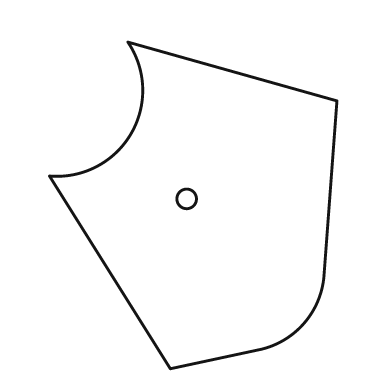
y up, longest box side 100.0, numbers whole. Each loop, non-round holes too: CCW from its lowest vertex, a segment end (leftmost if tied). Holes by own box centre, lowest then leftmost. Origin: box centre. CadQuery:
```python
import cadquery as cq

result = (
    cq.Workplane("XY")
    .moveTo(-7.0, -50.0)
    .lineTo(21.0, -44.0)
    .threePointArc((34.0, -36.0), (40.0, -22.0))
    .lineTo(44.0, 32.0)
    .lineTo(-20.0, 50.0)
    .threePointArc((-19.0, 22.0), (-44.0, 9.0))
    .close()
    .moveTo(-2.0, 2.0)
    .circle(3.0)
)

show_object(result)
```